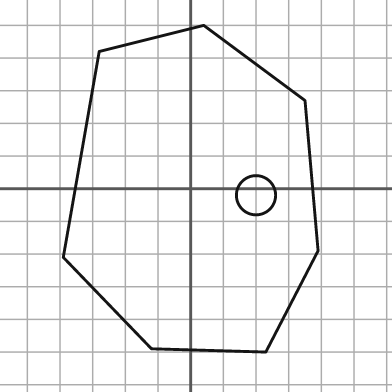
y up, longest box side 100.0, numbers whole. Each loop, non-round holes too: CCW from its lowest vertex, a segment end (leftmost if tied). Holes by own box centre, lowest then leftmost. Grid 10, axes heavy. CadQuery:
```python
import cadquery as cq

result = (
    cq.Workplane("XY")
    .moveTo(23.0, -50.0)
    .lineTo(39.0, -19.0)
    .lineTo(35.0, 27.0)
    .lineTo(4.0, 50.0)
    .lineTo(-28.0, 42.0)
    .lineTo(-39.0, -21.0)
    .lineTo(-12.0, -49.0)
    .close()
    .moveTo(20.0, -2.0)
    .circle(6.0)
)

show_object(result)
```